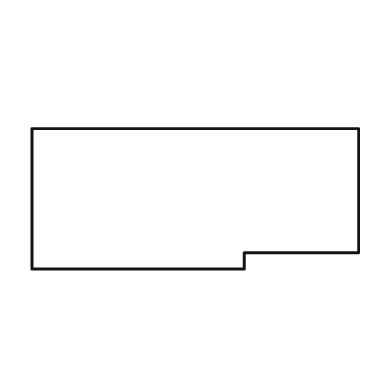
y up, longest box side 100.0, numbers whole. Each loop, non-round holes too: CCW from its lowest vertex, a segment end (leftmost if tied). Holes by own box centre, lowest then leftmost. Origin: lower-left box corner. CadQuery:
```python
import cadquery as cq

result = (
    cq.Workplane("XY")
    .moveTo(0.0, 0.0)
    .lineTo(65.0, 0.0)
    .lineTo(65.0, 5.0)
    .lineTo(100.0, 5.0)
    .lineTo(100.0, 43.0)
    .lineTo(0.0, 43.0)
    .close()
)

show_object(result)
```